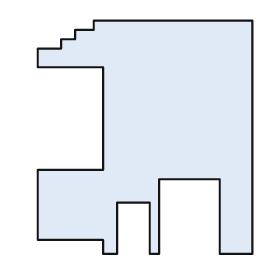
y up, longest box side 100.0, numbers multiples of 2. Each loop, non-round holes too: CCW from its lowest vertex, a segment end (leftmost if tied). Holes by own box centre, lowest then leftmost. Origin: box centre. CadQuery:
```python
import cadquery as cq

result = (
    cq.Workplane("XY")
    .moveTo(-18.0, -50.0)
    .lineTo(-12.0, -50.0)
    .lineTo(-12.0, -28.0)
    .lineTo(2.0, -28.0)
    .lineTo(2.0, -50.0)
    .lineTo(6.0, -50.0)
    .lineTo(6.0, -18.0)
    .lineTo(32.0, -18.0)
    .lineTo(32.0, -50.0)
    .lineTo(46.0, -50.0)
    .lineTo(46.0, 50.0)
    .lineTo(-22.0, 50.0)
    .lineTo(-22.0, 46.0)
    .lineTo(-30.0, 46.0)
    .lineTo(-30.0, 42.0)
    .lineTo(-36.0, 42.0)
    .lineTo(-36.0, 38.0)
    .lineTo(-46.0, 38.0)
    .lineTo(-46.0, 30.0)
    .lineTo(-18.0, 30.0)
    .lineTo(-18.0, -14.0)
    .lineTo(-46.0, -14.0)
    .lineTo(-46.0, -44.0)
    .lineTo(-18.0, -44.0)
    .close()
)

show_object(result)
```